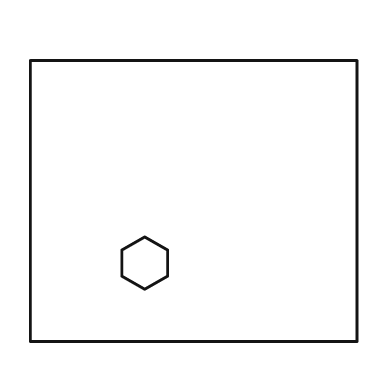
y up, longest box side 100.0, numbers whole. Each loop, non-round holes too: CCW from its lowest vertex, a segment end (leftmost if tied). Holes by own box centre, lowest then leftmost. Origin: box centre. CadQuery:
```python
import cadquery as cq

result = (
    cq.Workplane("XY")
    .moveTo(-50.0, -43.0)
    .lineTo(50.0, -43.0)
    .lineTo(50.0, 43.0)
    .lineTo(-50.0, 43.0)
    .close()
    .moveTo(-15.0, -27.0)
    .lineTo(-8.0, -23.0)
    .lineTo(-8.0, -15.0)
    .lineTo(-15.0, -11.0)
    .lineTo(-22.0, -15.0)
    .lineTo(-22.0, -23.0)
    .close()
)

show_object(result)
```